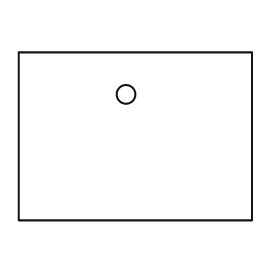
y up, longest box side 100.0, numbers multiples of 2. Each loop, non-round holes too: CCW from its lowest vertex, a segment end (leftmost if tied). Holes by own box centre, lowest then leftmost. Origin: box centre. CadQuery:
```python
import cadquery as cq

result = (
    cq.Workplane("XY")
    .moveTo(-50.0, -36.0)
    .lineTo(50.0, -36.0)
    .lineTo(50.0, 36.0)
    .lineTo(-50.0, 36.0)
    .close()
    .moveTo(-4.0, 18.0)
    .circle(4.0)
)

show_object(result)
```